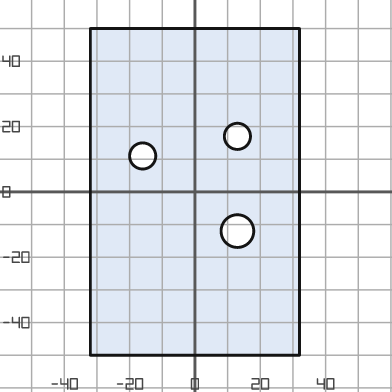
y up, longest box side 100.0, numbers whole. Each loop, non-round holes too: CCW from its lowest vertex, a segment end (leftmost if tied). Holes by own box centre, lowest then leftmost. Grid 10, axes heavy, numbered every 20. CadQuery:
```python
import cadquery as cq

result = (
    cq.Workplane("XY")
    .moveTo(-32.0, -50.0)
    .lineTo(32.0, -50.0)
    .lineTo(32.0, 50.0)
    .lineTo(-32.0, 50.0)
    .close()
    .moveTo(13.0, -12.0)
    .circle(5.0)
    .moveTo(-16.0, 11.0)
    .circle(4.0)
    .moveTo(13.0, 17.0)
    .circle(4.0)
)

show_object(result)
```